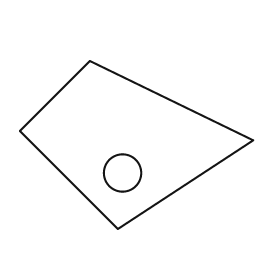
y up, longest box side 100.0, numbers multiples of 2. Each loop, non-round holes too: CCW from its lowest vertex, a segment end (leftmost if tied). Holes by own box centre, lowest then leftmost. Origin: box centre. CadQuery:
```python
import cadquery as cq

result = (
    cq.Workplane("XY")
    .moveTo(-8.0, -36.0)
    .lineTo(50.0, 2.0)
    .lineTo(-20.0, 36.0)
    .lineTo(-50.0, 6.0)
    .close()
    .moveTo(-6.0, -12.0)
    .circle(8.0)
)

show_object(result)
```